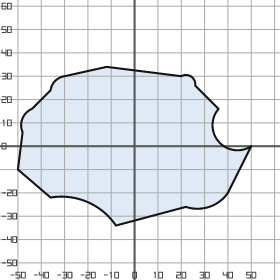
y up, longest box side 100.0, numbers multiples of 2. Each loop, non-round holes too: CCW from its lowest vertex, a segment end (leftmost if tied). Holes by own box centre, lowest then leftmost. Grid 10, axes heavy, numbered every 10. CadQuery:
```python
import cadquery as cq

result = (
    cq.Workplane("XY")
    .moveTo(-8.0, -34.0)
    .lineTo(22.0, -26.0)
    .threePointArc((32.0, -26.0), (40.0, -20.0))
    .lineTo(50.0, 0.0)
    .threePointArc((36.0, 2.0), (36.0, 16.0))
    .lineTo(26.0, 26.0)
    .threePointArc((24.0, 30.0), (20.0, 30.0))
    .lineTo(-12.0, 34.0)
    .lineTo(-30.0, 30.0)
    .threePointArc((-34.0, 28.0), (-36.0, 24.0))
    .lineTo(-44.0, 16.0)
    .threePointArc((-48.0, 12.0), (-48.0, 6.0))
    .lineTo(-50.0, -10.0)
    .lineTo(-36.0, -22.0)
    .threePointArc((-20.0, -24.0), (-8.0, -34.0))
    .close()
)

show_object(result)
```